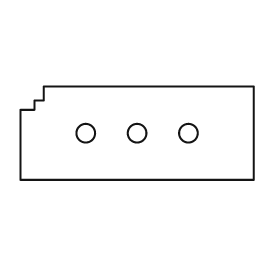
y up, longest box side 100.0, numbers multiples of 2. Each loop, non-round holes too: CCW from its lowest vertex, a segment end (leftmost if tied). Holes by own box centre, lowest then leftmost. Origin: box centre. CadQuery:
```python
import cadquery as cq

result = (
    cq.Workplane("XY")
    .moveTo(-50.0, -20.0)
    .lineTo(50.0, -20.0)
    .lineTo(50.0, 20.0)
    .lineTo(-40.0, 20.0)
    .lineTo(-40.0, 14.0)
    .lineTo(-44.0, 14.0)
    .lineTo(-44.0, 10.0)
    .lineTo(-50.0, 10.0)
    .close()
    .moveTo(-22.0, 0.0)
    .circle(4.0)
    .moveTo(0.0, 0.0)
    .circle(4.0)
    .moveTo(22.0, 0.0)
    .circle(4.0)
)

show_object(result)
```